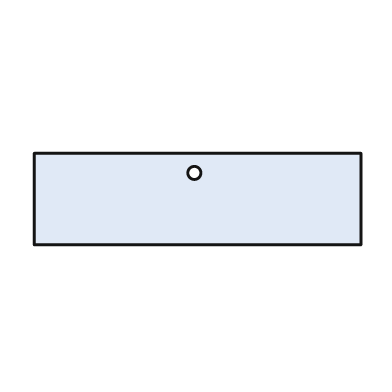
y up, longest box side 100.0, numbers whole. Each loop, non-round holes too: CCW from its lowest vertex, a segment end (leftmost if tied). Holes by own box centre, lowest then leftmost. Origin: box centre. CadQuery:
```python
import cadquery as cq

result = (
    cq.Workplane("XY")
    .moveTo(-50.0, -14.0)
    .lineTo(50.0, -14.0)
    .lineTo(50.0, 14.0)
    .lineTo(-50.0, 14.0)
    .close()
    .moveTo(-1.0, 8.0)
    .circle(2.0)
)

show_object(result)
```